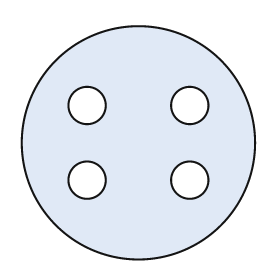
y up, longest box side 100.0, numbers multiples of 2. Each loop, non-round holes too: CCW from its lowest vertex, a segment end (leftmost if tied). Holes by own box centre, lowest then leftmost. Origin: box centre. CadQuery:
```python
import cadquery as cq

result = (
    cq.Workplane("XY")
    .moveTo(0.0, 0.0)
    .circle(50.0)
    .moveTo(-22.0, -16.0)
    .circle(8.0)
    .moveTo(22.0, -16.0)
    .circle(8.0)
    .moveTo(-22.0, 16.0)
    .circle(8.0)
    .moveTo(22.0, 16.0)
    .circle(8.0)
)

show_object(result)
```